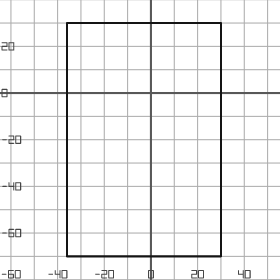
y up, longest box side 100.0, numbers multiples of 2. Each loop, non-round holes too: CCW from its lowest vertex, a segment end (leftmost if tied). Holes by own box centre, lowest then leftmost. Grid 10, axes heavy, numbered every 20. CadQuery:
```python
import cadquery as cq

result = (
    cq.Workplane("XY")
    .moveTo(-36.0, -70.0)
    .lineTo(30.0, -70.0)
    .lineTo(30.0, 30.0)
    .lineTo(-36.0, 30.0)
    .close()
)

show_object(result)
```